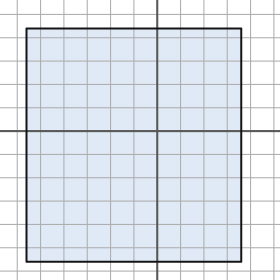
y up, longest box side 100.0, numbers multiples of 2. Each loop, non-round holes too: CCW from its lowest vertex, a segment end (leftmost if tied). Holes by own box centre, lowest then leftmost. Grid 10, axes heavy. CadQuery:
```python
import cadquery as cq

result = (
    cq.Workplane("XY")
    .moveTo(-56.0, -56.0)
    .lineTo(36.0, -56.0)
    .lineTo(36.0, 44.0)
    .lineTo(-56.0, 44.0)
    .close()
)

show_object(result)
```